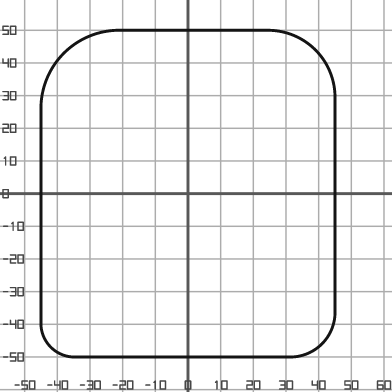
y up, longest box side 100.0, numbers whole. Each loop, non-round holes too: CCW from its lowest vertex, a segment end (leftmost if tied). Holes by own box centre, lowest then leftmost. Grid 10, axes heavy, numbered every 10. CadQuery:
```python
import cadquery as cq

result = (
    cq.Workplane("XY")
    .moveTo(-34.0, -50.0)
    .lineTo(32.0, -50.0)
    .threePointArc((41.0, -46.0), (45.0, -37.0))
    .lineTo(45.0, 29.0)
    .threePointArc((39.0, 44.0), (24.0, 50.0))
    .lineTo(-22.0, 50.0)
    .threePointArc((-38.0, 43.0), (-45.0, 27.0))
    .lineTo(-45.0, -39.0)
    .threePointArc((-42.0, -47.0), (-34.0, -50.0))
    .close()
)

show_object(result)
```